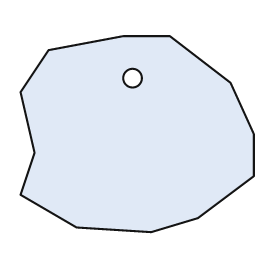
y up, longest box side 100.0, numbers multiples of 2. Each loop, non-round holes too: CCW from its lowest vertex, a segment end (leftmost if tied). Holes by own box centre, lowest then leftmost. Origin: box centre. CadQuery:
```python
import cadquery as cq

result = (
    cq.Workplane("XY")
    .moveTo(6.0, -42.0)
    .lineTo(26.0, -36.0)
    .lineTo(50.0, -18.0)
    .lineTo(50.0, 0.0)
    .lineTo(40.0, 22.0)
    .lineTo(14.0, 42.0)
    .lineTo(-6.0, 42.0)
    .lineTo(-38.0, 36.0)
    .lineTo(-50.0, 18.0)
    .lineTo(-44.0, -8.0)
    .lineTo(-50.0, -26.0)
    .lineTo(-26.0, -40.0)
    .close()
    .moveTo(-2.0, 24.0)
    .circle(4.0)
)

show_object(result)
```